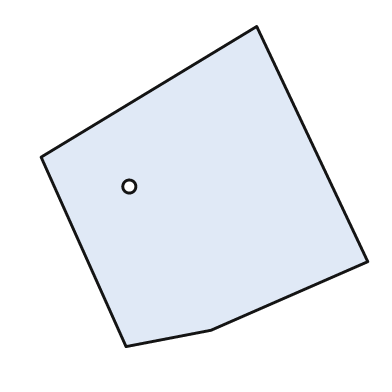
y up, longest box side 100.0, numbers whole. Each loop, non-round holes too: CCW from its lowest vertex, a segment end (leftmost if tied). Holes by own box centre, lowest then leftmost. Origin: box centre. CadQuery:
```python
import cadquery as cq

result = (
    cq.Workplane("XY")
    .moveTo(-24.0, -49.0)
    .lineTo(2.0, -44.0)
    .lineTo(50.0, -23.0)
    .lineTo(16.0, 49.0)
    .lineTo(-50.0, 9.0)
    .close()
    .moveTo(-23.0, 0.0)
    .circle(2.0)
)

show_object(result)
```